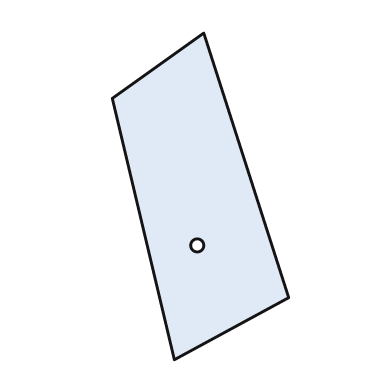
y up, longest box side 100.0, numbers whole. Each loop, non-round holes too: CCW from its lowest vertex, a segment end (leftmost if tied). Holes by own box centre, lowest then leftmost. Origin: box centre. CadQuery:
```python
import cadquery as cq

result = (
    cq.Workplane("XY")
    .moveTo(-8.0, -50.0)
    .lineTo(27.0, -31.0)
    .lineTo(1.0, 50.0)
    .lineTo(-27.0, 30.0)
    .close()
    .moveTo(-1.0, -15.0)
    .circle(2.0)
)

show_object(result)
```